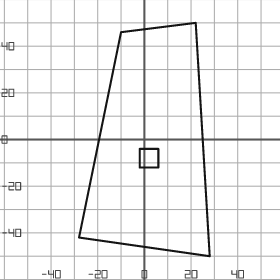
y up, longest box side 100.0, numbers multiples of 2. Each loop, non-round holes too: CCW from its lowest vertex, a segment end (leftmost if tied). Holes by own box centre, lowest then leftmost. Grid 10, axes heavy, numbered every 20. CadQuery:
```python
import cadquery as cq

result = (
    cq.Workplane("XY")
    .moveTo(28.0, -50.0)
    .lineTo(22.0, 50.0)
    .lineTo(-10.0, 46.0)
    .lineTo(-28.0, -42.0)
    .close()
    .moveTo(-2.0, -12.0)
    .lineTo(6.0, -12.0)
    .lineTo(6.0, -4.0)
    .lineTo(-2.0, -4.0)
    .close()
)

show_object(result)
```